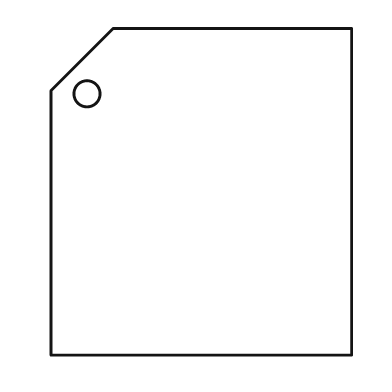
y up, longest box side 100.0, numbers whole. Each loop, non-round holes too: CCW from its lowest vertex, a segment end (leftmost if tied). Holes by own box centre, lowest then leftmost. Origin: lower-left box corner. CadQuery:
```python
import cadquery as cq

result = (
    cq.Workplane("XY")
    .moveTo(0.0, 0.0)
    .lineTo(92.0, 0.0)
    .lineTo(92.0, 100.0)
    .lineTo(19.0, 100.0)
    .lineTo(0.0, 81.0)
    .close()
    .moveTo(11.0, 80.0)
    .circle(4.0)
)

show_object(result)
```